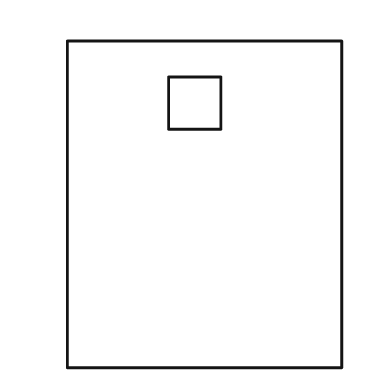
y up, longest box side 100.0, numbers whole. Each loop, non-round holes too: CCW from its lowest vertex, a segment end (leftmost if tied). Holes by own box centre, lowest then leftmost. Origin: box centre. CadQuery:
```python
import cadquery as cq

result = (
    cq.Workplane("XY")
    .moveTo(-42.0, -50.0)
    .lineTo(42.0, -50.0)
    .lineTo(42.0, 50.0)
    .lineTo(-42.0, 50.0)
    .close()
    .moveTo(-11.0, 23.0)
    .lineTo(5.0, 23.0)
    .lineTo(5.0, 39.0)
    .lineTo(-11.0, 39.0)
    .close()
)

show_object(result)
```